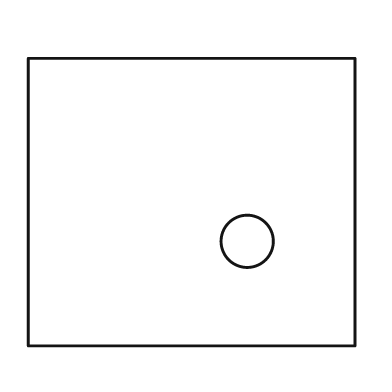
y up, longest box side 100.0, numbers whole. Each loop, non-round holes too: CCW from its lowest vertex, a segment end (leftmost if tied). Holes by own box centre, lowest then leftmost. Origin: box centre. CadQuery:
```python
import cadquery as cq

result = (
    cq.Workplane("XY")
    .moveTo(-50.0, -44.0)
    .lineTo(50.0, -44.0)
    .lineTo(50.0, 44.0)
    .lineTo(-50.0, 44.0)
    .close()
    .moveTo(17.0, -12.0)
    .circle(8.0)
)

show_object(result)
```